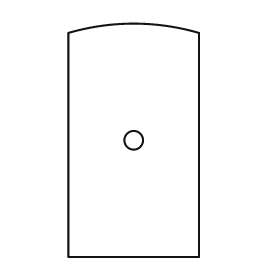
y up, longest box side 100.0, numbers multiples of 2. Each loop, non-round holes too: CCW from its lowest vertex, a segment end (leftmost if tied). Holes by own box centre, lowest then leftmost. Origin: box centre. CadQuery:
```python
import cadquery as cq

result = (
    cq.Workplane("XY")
    .moveTo(-28.0, -50.0)
    .lineTo(28.0, -50.0)
    .lineTo(28.0, 46.0)
    .threePointArc((0.0, 50.0), (-28.0, 46.0))
    .close()
    .moveTo(0.0, 0.0)
    .circle(4.0)
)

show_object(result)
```